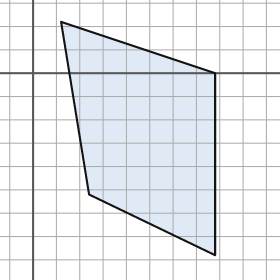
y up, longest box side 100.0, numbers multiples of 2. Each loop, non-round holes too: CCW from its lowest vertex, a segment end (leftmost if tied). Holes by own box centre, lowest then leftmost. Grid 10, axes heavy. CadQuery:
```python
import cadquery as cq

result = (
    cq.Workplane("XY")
    .moveTo(78.0, -78.0)
    .lineTo(78.0, 0.0)
    .lineTo(12.0, 22.0)
    .lineTo(24.0, -52.0)
    .close()
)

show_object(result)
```